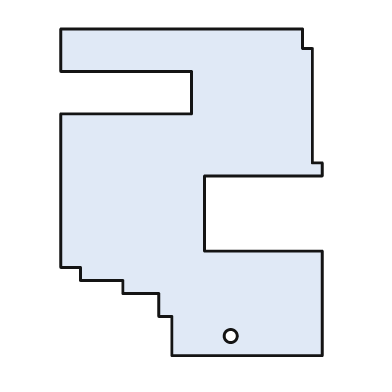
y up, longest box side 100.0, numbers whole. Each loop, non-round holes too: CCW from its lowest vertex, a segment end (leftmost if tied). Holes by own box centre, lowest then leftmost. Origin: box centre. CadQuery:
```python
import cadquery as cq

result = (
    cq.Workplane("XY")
    .moveTo(-6.0, -50.0)
    .lineTo(40.0, -50.0)
    .lineTo(40.0, -18.0)
    .lineTo(4.0, -18.0)
    .lineTo(4.0, 5.0)
    .lineTo(40.0, 5.0)
    .lineTo(40.0, 9.0)
    .lineTo(37.0, 9.0)
    .lineTo(37.0, 44.0)
    .lineTo(34.0, 44.0)
    .lineTo(34.0, 50.0)
    .lineTo(-40.0, 50.0)
    .lineTo(-40.0, 37.0)
    .lineTo(0.0, 37.0)
    .lineTo(0.0, 24.0)
    .lineTo(-40.0, 24.0)
    .lineTo(-40.0, -23.0)
    .lineTo(-34.0, -23.0)
    .lineTo(-34.0, -27.0)
    .lineTo(-21.0, -27.0)
    .lineTo(-21.0, -31.0)
    .lineTo(-10.0, -31.0)
    .lineTo(-10.0, -38.0)
    .lineTo(-6.0, -38.0)
    .close()
    .moveTo(12.0, -44.0)
    .circle(2.0)
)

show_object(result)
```